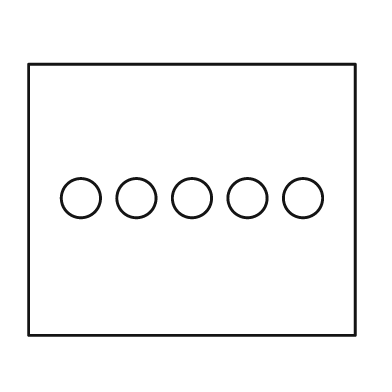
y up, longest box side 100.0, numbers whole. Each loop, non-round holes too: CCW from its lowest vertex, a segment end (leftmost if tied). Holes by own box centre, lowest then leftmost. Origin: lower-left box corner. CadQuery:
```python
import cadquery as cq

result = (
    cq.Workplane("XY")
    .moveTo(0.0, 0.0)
    .lineTo(100.0, 0.0)
    .lineTo(100.0, 83.0)
    .lineTo(0.0, 83.0)
    .close()
    .moveTo(16.0, 42.0)
    .circle(6.0)
    .moveTo(33.0, 42.0)
    .circle(6.0)
    .moveTo(50.0, 42.0)
    .circle(6.0)
    .moveTo(67.0, 42.0)
    .circle(6.0)
    .moveTo(84.0, 42.0)
    .circle(6.0)
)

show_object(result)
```